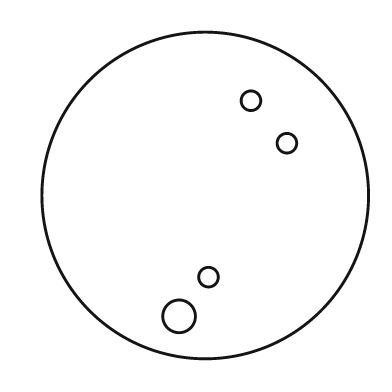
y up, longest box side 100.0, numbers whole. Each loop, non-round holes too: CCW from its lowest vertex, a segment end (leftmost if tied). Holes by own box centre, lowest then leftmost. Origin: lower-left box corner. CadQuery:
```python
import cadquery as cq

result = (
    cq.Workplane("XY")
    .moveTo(50.0, 50.0)
    .circle(50.0)
    .moveTo(42.0, 13.0)
    .circle(5.0)
    .moveTo(51.0, 25.0)
    .circle(3.0)
    .moveTo(75.0, 66.0)
    .circle(3.0)
    .moveTo(64.0, 79.0)
    .circle(3.0)
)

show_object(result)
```